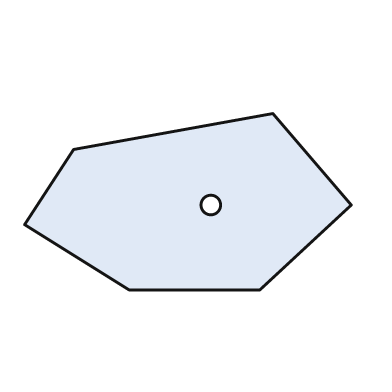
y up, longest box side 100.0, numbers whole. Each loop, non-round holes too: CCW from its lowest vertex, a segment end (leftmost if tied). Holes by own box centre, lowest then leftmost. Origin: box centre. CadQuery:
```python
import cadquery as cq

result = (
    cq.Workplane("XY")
    .moveTo(-18.0, -27.0)
    .lineTo(22.0, -27.0)
    .lineTo(50.0, -1.0)
    .lineTo(26.0, 27.0)
    .lineTo(-35.0, 16.0)
    .lineTo(-50.0, -7.0)
    .close()
    .moveTo(7.0, -1.0)
    .circle(3.0)
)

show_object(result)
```